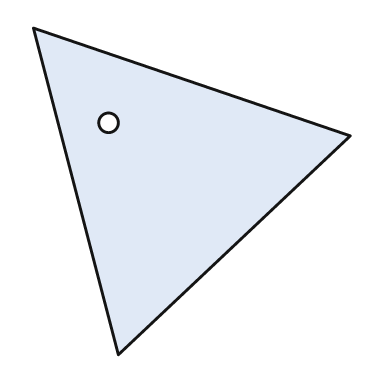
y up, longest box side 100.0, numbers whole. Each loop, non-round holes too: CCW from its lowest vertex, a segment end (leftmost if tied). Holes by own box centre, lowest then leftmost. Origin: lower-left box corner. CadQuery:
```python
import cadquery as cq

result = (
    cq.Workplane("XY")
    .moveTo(26.0, 0.0)
    .lineTo(97.0, 67.0)
    .lineTo(0.0, 100.0)
    .close()
    .moveTo(23.0, 71.0)
    .circle(3.0)
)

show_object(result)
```